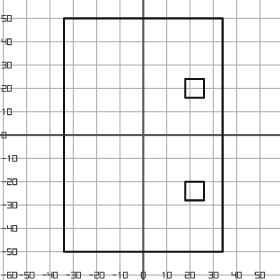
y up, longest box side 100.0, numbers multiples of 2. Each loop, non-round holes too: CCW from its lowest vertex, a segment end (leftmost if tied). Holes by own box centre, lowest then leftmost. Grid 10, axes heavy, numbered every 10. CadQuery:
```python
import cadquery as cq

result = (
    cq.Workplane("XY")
    .moveTo(-34.0, -50.0)
    .lineTo(34.0, -50.0)
    .lineTo(34.0, 50.0)
    .lineTo(-34.0, 50.0)
    .close()
    .moveTo(18.0, -28.0)
    .lineTo(26.0, -28.0)
    .lineTo(26.0, -20.0)
    .lineTo(18.0, -20.0)
    .close()
    .moveTo(18.0, 16.0)
    .lineTo(26.0, 16.0)
    .lineTo(26.0, 24.0)
    .lineTo(18.0, 24.0)
    .close()
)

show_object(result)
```